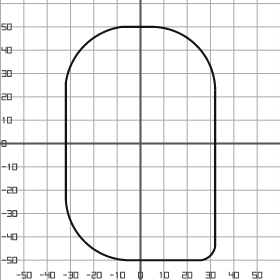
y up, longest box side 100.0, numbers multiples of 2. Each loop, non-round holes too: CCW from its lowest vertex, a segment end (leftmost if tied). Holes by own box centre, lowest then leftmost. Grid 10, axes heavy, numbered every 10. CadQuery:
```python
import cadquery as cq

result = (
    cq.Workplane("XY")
    .moveTo(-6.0, -50.0)
    .lineTo(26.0, -50.0)
    .threePointArc((30.0, -48.0), (32.0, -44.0))
    .lineTo(32.0, 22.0)
    .threePointArc((24.0, 42.0), (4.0, 50.0))
    .lineTo(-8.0, 50.0)
    .threePointArc((-24.0, 42.0), (-32.0, 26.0))
    .lineTo(-32.0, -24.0)
    .threePointArc((-24.0, -42.0), (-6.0, -50.0))
    .close()
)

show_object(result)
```